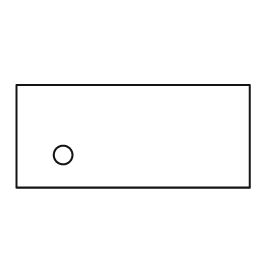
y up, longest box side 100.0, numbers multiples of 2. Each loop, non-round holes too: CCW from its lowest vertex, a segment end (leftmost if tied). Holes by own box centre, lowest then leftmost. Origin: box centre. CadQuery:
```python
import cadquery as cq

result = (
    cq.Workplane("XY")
    .moveTo(-50.0, -22.0)
    .lineTo(50.0, -22.0)
    .lineTo(50.0, 22.0)
    .lineTo(-50.0, 22.0)
    .close()
    .moveTo(-30.0, -8.0)
    .circle(4.0)
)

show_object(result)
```